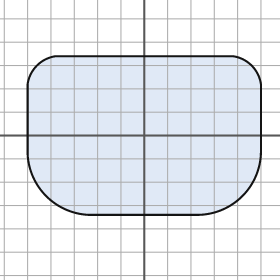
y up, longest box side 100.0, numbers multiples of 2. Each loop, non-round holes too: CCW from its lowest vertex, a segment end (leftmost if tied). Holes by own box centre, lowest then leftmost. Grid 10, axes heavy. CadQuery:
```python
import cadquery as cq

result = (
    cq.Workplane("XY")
    .moveTo(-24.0, -34.0)
    .lineTo(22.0, -34.0)
    .threePointArc((42.0, -26.0), (50.0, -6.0))
    .lineTo(50.0, 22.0)
    .threePointArc((46.0, 30.0), (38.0, 34.0))
    .lineTo(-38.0, 34.0)
    .threePointArc((-46.0, 30.0), (-50.0, 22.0))
    .lineTo(-50.0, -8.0)
    .threePointArc((-42.0, -26.0), (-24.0, -34.0))
    .close()
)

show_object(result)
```